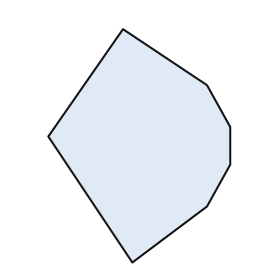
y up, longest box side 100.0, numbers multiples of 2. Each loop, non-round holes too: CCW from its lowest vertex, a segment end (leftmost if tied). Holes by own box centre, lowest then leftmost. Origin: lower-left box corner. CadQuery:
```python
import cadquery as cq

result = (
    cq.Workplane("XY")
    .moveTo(36.0, 0.0)
    .lineTo(68.0, 24.0)
    .lineTo(78.0, 42.0)
    .lineTo(78.0, 58.0)
    .lineTo(68.0, 76.0)
    .lineTo(32.0, 100.0)
    .lineTo(0.0, 54.0)
    .close()
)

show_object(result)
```